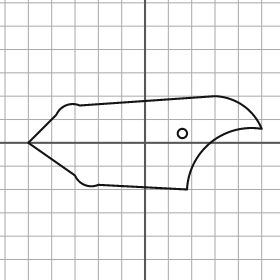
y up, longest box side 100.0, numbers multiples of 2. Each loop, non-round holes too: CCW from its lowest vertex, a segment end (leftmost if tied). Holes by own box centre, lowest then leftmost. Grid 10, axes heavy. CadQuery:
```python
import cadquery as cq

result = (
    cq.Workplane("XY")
    .moveTo(18.0, -20.0)
    .threePointArc((28.0, 0.0), (50.0, 6.0))
    .threePointArc((42.0, 16.0), (30.0, 20.0))
    .lineTo(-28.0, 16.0)
    .threePointArc((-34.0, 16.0), (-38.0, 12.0))
    .lineTo(-50.0, 0.0)
    .lineTo(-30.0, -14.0)
    .threePointArc((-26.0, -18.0), (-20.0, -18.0))
    .close()
    .moveTo(16.0, 4.0)
    .circle(2.0)
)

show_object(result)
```